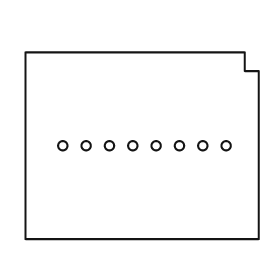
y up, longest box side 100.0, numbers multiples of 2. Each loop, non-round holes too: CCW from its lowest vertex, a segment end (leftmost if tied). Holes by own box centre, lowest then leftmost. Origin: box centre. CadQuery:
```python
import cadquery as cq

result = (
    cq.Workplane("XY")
    .moveTo(-50.0, -40.0)
    .lineTo(50.0, -40.0)
    .lineTo(50.0, 32.0)
    .lineTo(44.0, 32.0)
    .lineTo(44.0, 40.0)
    .lineTo(-50.0, 40.0)
    .close()
    .moveTo(-34.0, 0.0)
    .circle(2.0)
    .moveTo(-24.0, 0.0)
    .circle(2.0)
    .moveTo(-14.0, 0.0)
    .circle(2.0)
    .moveTo(-4.0, 0.0)
    .circle(2.0)
    .moveTo(6.0, 0.0)
    .circle(2.0)
    .moveTo(16.0, 0.0)
    .circle(2.0)
    .moveTo(26.0, 0.0)
    .circle(2.0)
    .moveTo(36.0, 0.0)
    .circle(2.0)
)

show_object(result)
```